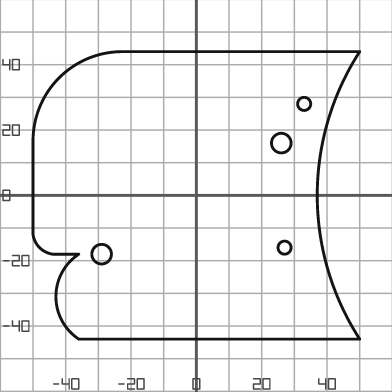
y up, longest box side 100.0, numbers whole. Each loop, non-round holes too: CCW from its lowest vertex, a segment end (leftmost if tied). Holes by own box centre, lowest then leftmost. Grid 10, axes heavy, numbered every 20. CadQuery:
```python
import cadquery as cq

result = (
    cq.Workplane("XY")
    .moveTo(-36.0, -44.0)
    .lineTo(50.0, -44.0)
    .threePointArc((37.0, 0.0), (50.0, 44.0))
    .lineTo(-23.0, 44.0)
    .threePointArc((-42.0, 36.0), (-50.0, 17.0))
    .lineTo(-50.0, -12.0)
    .threePointArc((-48.0, -16.0), (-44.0, -18.0))
    .lineTo(-36.0, -18.0)
    .threePointArc((-43.0, -31.0), (-36.0, -44.0))
    .close()
    .moveTo(-29.0, -18.0)
    .circle(3.0)
    .moveTo(27.0, -16.0)
    .circle(2.0)
    .moveTo(26.0, 16.0)
    .circle(3.0)
    .moveTo(33.0, 28.0)
    .circle(2.0)
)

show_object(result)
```